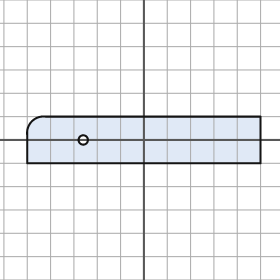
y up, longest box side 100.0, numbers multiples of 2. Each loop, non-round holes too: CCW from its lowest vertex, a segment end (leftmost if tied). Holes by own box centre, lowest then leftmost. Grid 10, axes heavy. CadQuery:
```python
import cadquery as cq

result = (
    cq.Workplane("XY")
    .moveTo(-50.0, -10.0)
    .lineTo(50.0, -10.0)
    .lineTo(50.0, 10.0)
    .lineTo(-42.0, 10.0)
    .threePointArc((-48.0, 8.0), (-50.0, 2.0))
    .close()
    .moveTo(-26.0, 0.0)
    .circle(2.0)
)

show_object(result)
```